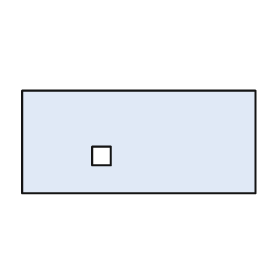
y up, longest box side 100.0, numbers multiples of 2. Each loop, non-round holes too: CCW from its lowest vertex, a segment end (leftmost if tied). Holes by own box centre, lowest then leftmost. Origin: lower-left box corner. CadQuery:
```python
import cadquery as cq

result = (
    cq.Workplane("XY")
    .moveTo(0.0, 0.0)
    .lineTo(100.0, 0.0)
    .lineTo(100.0, 44.0)
    .lineTo(0.0, 44.0)
    .close()
    .moveTo(30.0, 12.0)
    .lineTo(38.0, 12.0)
    .lineTo(38.0, 20.0)
    .lineTo(30.0, 20.0)
    .close()
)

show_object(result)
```